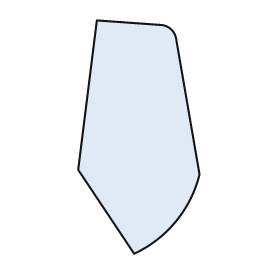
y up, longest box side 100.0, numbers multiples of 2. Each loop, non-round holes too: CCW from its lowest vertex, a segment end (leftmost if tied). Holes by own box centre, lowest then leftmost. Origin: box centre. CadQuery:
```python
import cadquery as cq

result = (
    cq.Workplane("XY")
    .moveTo(-2.0, -50.0)
    .threePointArc((16.0, -36.0), (26.0, -16.0))
    .lineTo(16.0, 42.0)
    .threePointArc((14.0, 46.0), (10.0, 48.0))
    .lineTo(-18.0, 50.0)
    .lineTo(-26.0, -14.0)
    .close()
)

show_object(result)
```